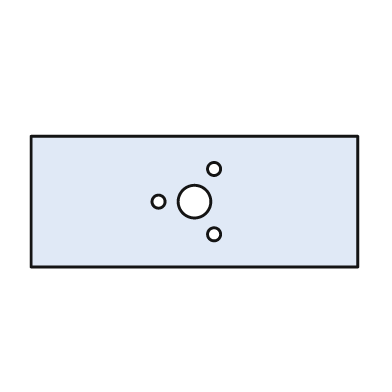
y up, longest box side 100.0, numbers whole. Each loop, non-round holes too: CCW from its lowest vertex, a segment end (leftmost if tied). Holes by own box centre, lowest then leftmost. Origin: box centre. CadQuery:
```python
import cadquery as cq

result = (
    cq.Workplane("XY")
    .moveTo(-50.0, -20.0)
    .lineTo(50.0, -20.0)
    .lineTo(50.0, 20.0)
    .lineTo(-50.0, 20.0)
    .close()
    .moveTo(6.0, -10.0)
    .circle(2.0)
    .moveTo(-11.0, 0.0)
    .circle(2.0)
    .moveTo(0.0, 0.0)
    .circle(5.0)
    .moveTo(6.0, 10.0)
    .circle(2.0)
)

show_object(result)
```